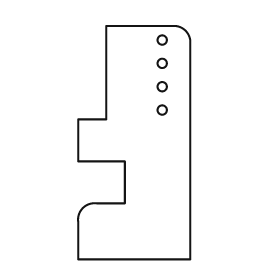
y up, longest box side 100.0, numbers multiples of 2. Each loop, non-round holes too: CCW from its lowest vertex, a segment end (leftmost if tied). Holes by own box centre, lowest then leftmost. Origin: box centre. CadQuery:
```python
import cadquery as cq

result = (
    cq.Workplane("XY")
    .moveTo(-24.0, -50.0)
    .lineTo(24.0, -50.0)
    .lineTo(24.0, 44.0)
    .threePointArc((22.0, 48.0), (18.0, 50.0))
    .lineTo(-12.0, 50.0)
    .lineTo(-12.0, 10.0)
    .lineTo(-24.0, 10.0)
    .lineTo(-24.0, -8.0)
    .lineTo(-4.0, -8.0)
    .lineTo(-4.0, -26.0)
    .lineTo(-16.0, -26.0)
    .threePointArc((-22.0, -28.0), (-24.0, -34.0))
    .close()
    .moveTo(12.0, 14.0)
    .circle(2.0)
    .moveTo(12.0, 24.0)
    .circle(2.0)
    .moveTo(12.0, 34.0)
    .circle(2.0)
    .moveTo(12.0, 44.0)
    .circle(2.0)
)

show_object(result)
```